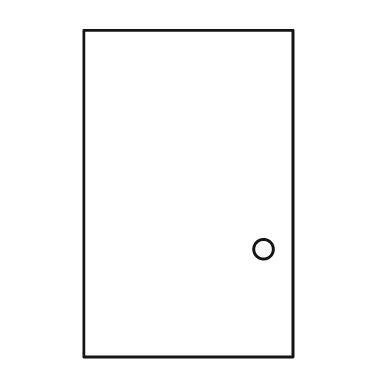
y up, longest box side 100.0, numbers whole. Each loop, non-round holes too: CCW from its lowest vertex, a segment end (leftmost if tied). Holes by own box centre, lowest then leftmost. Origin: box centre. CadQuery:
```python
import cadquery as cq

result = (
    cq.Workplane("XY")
    .moveTo(-32.0, -50.0)
    .lineTo(32.0, -50.0)
    .lineTo(32.0, 50.0)
    .lineTo(-32.0, 50.0)
    .close()
    .moveTo(23.0, -17.0)
    .circle(3.0)
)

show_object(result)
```